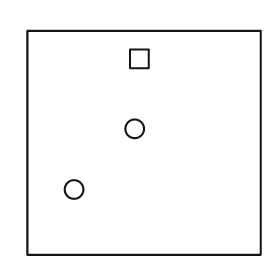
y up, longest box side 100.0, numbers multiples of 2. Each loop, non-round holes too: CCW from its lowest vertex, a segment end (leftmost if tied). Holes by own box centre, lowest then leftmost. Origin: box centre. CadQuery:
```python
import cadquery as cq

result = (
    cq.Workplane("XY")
    .moveTo(-50.0, -48.0)
    .lineTo(50.0, -48.0)
    .lineTo(50.0, 48.0)
    .lineTo(-50.0, 48.0)
    .close()
    .moveTo(-30.0, -20.0)
    .circle(4.0)
    .moveTo(-4.0, 6.0)
    .circle(4.0)
    .moveTo(-6.0, 32.0)
    .lineTo(2.0, 32.0)
    .lineTo(2.0, 40.0)
    .lineTo(-6.0, 40.0)
    .close()
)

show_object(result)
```